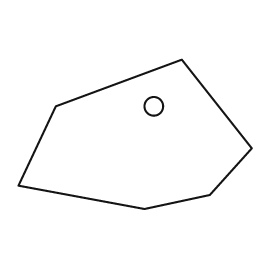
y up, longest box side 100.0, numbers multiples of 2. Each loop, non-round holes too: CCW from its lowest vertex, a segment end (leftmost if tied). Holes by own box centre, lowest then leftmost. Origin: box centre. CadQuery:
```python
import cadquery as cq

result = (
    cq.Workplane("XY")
    .moveTo(4.0, -32.0)
    .lineTo(32.0, -26.0)
    .lineTo(50.0, -6.0)
    .lineTo(20.0, 32.0)
    .lineTo(-34.0, 12.0)
    .lineTo(-50.0, -22.0)
    .close()
    .moveTo(8.0, 12.0)
    .circle(4.0)
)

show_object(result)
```